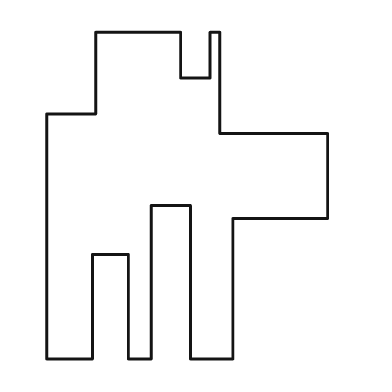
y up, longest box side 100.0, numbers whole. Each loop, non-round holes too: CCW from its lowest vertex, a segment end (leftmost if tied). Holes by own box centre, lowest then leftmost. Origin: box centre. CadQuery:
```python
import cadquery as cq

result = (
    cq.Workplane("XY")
    .moveTo(-43.0, -50.0)
    .lineTo(-29.0, -50.0)
    .lineTo(-29.0, -18.0)
    .lineTo(-18.0, -18.0)
    .lineTo(-18.0, -50.0)
    .lineTo(-11.0, -50.0)
    .lineTo(-11.0, -3.0)
    .lineTo(1.0, -3.0)
    .lineTo(1.0, -50.0)
    .lineTo(14.0, -50.0)
    .lineTo(14.0, -7.0)
    .lineTo(43.0, -7.0)
    .lineTo(43.0, 19.0)
    .lineTo(10.0, 19.0)
    .lineTo(10.0, 50.0)
    .lineTo(7.0, 50.0)
    .lineTo(7.0, 36.0)
    .lineTo(-2.0, 36.0)
    .lineTo(-2.0, 50.0)
    .lineTo(-28.0, 50.0)
    .lineTo(-28.0, 25.0)
    .lineTo(-43.0, 25.0)
    .close()
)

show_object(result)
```